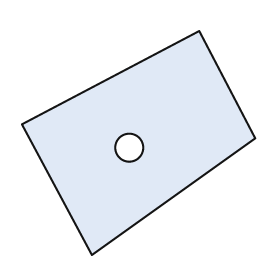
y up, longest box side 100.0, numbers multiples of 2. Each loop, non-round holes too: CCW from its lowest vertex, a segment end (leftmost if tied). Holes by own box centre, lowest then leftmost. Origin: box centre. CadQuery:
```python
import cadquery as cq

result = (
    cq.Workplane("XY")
    .moveTo(-20.0, -48.0)
    .lineTo(50.0, 2.0)
    .lineTo(26.0, 48.0)
    .lineTo(-50.0, 8.0)
    .close()
    .moveTo(-4.0, -2.0)
    .circle(6.0)
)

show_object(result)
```